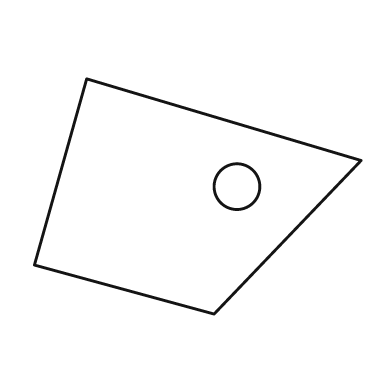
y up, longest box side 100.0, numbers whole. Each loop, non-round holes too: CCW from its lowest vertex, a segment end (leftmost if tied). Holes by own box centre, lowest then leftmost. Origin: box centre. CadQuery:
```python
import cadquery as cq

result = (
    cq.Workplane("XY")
    .moveTo(5.0, -36.0)
    .lineTo(50.0, 11.0)
    .lineTo(-34.0, 36.0)
    .lineTo(-50.0, -21.0)
    .close()
    .moveTo(12.0, 3.0)
    .circle(7.0)
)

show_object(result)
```